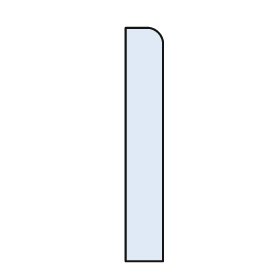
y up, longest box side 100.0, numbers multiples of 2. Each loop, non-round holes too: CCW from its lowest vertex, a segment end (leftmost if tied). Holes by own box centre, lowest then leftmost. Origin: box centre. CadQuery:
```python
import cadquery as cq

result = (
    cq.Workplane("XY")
    .moveTo(-8.0, -50.0)
    .lineTo(8.0, -50.0)
    .lineTo(8.0, 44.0)
    .threePointArc((6.0, 48.0), (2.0, 50.0))
    .lineTo(-8.0, 50.0)
    .close()
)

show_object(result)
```